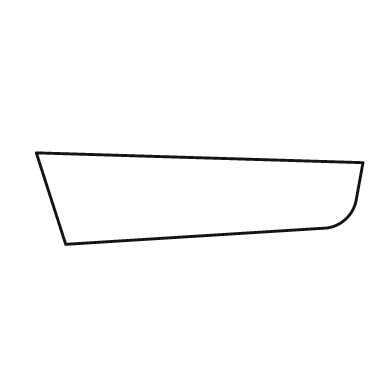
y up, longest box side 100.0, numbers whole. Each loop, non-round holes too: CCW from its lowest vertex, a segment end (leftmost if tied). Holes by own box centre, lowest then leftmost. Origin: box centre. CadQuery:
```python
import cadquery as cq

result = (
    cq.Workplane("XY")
    .moveTo(-41.0, -14.0)
    .lineTo(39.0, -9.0)
    .threePointArc((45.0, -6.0), (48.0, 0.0))
    .lineTo(50.0, 11.0)
    .lineTo(-50.0, 14.0)
    .close()
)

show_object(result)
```